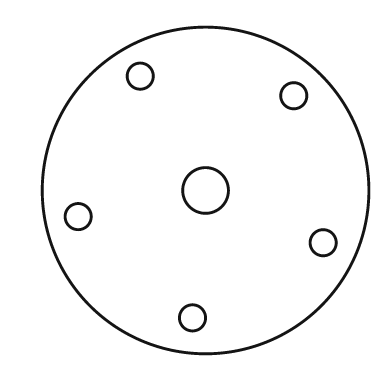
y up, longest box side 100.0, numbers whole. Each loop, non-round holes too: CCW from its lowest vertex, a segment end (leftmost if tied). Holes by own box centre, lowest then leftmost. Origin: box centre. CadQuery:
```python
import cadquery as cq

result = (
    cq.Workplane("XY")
    .moveTo(0.0, 0.0)
    .circle(50.0)
    .moveTo(-4.0, -39.0)
    .circle(4.0)
    .moveTo(36.0, -16.0)
    .circle(4.0)
    .moveTo(-39.0, -8.0)
    .circle(4.0)
    .moveTo(0.0, 0.0)
    .circle(7.0)
    .moveTo(27.0, 29.0)
    .circle(4.0)
    .moveTo(-20.0, 35.0)
    .circle(4.0)
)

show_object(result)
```